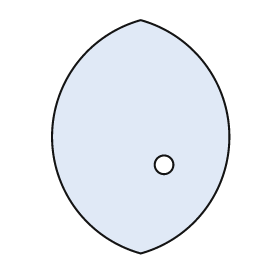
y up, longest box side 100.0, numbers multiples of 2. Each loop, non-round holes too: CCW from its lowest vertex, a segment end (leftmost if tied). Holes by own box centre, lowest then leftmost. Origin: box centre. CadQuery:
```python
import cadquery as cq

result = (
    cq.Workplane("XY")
    .moveTo(0.0, -50.0)
    .threePointArc((38.0, 0.0), (0.0, 50.0))
    .threePointArc((-38.0, 0.0), (0.0, -50.0))
    .close()
    .moveTo(10.0, -12.0)
    .circle(4.0)
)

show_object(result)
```